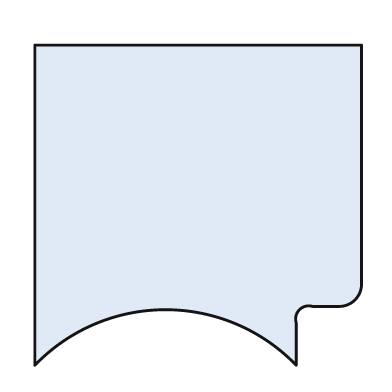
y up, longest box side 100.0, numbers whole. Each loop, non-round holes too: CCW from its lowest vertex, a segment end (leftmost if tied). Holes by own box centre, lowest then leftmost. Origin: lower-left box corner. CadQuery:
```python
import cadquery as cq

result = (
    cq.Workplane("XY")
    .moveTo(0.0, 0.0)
    .threePointArc((40.0, 17.0), (80.0, 0.0))
    .lineTo(80.0, 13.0)
    .threePointArc((81.0, 17.0), (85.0, 18.0))
    .lineTo(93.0, 18.0)
    .threePointArc((98.0, 20.0), (100.0, 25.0))
    .lineTo(100.0, 98.0)
    .lineTo(0.0, 98.0)
    .close()
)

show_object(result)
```